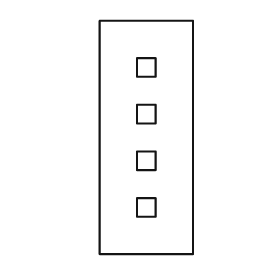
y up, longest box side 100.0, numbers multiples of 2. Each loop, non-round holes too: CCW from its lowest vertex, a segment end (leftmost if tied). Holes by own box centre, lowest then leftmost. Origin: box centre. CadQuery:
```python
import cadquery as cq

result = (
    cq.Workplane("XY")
    .moveTo(-20.0, -50.0)
    .lineTo(20.0, -50.0)
    .lineTo(20.0, 50.0)
    .lineTo(-20.0, 50.0)
    .close()
    .moveTo(-4.0, -34.0)
    .lineTo(4.0, -34.0)
    .lineTo(4.0, -26.0)
    .lineTo(-4.0, -26.0)
    .close()
    .moveTo(-4.0, -14.0)
    .lineTo(4.0, -14.0)
    .lineTo(4.0, -6.0)
    .lineTo(-4.0, -6.0)
    .close()
    .moveTo(-4.0, 6.0)
    .lineTo(4.0, 6.0)
    .lineTo(4.0, 14.0)
    .lineTo(-4.0, 14.0)
    .close()
    .moveTo(-4.0, 26.0)
    .lineTo(4.0, 26.0)
    .lineTo(4.0, 34.0)
    .lineTo(-4.0, 34.0)
    .close()
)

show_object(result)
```